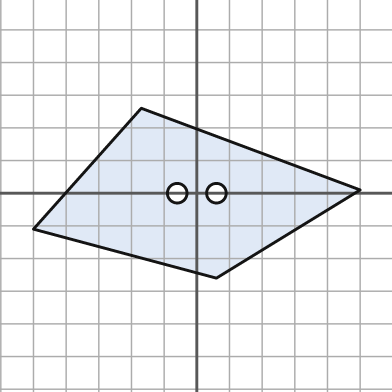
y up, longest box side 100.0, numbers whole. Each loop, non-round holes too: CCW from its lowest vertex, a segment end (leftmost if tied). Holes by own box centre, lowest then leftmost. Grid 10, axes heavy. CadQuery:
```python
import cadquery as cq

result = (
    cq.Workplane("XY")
    .moveTo(6.0, -26.0)
    .lineTo(50.0, 1.0)
    .lineTo(-17.0, 26.0)
    .lineTo(-50.0, -11.0)
    .close()
    .moveTo(-6.0, 0.0)
    .circle(3.0)
    .moveTo(6.0, 0.0)
    .circle(3.0)
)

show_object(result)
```